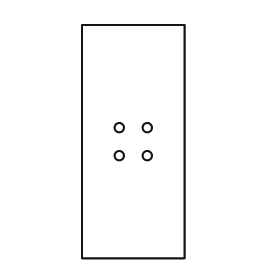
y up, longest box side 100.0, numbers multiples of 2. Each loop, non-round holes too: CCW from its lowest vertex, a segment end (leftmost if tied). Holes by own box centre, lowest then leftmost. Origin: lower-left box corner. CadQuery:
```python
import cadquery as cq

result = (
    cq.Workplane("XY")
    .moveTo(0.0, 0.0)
    .lineTo(44.0, 0.0)
    .lineTo(44.0, 100.0)
    .lineTo(0.0, 100.0)
    .close()
    .moveTo(16.0, 44.0)
    .circle(2.0)
    .moveTo(28.0, 44.0)
    .circle(2.0)
    .moveTo(16.0, 56.0)
    .circle(2.0)
    .moveTo(28.0, 56.0)
    .circle(2.0)
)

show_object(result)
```